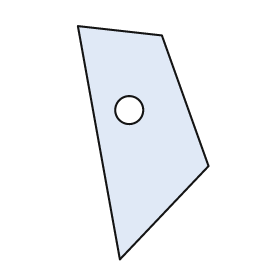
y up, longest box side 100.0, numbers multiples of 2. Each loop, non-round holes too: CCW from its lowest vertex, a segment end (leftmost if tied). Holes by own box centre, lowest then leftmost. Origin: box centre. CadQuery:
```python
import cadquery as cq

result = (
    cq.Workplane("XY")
    .moveTo(-10.0, -50.0)
    .lineTo(28.0, -10.0)
    .lineTo(8.0, 46.0)
    .lineTo(-28.0, 50.0)
    .close()
    .moveTo(-6.0, 14.0)
    .circle(6.0)
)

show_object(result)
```